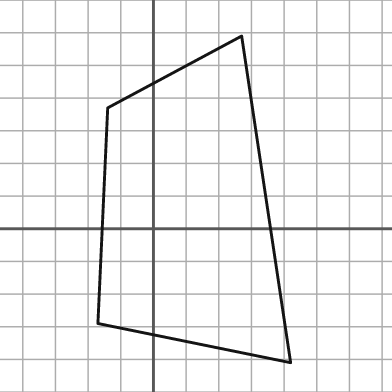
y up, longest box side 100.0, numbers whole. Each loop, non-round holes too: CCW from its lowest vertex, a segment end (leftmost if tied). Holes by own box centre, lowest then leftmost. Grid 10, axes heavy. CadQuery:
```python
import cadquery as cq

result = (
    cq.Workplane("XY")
    .moveTo(42.0, -41.0)
    .lineTo(27.0, 59.0)
    .lineTo(-14.0, 37.0)
    .lineTo(-17.0, -29.0)
    .close()
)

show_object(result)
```